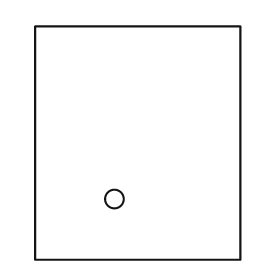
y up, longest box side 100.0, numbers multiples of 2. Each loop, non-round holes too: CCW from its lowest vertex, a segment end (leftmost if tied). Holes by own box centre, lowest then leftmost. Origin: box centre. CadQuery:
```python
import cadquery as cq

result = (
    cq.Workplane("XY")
    .moveTo(-44.0, -50.0)
    .lineTo(44.0, -50.0)
    .lineTo(44.0, 50.0)
    .lineTo(-44.0, 50.0)
    .close()
    .moveTo(-10.0, -24.0)
    .circle(4.0)
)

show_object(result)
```